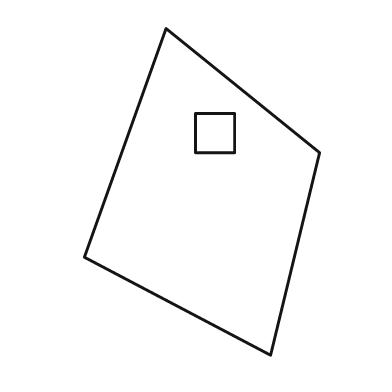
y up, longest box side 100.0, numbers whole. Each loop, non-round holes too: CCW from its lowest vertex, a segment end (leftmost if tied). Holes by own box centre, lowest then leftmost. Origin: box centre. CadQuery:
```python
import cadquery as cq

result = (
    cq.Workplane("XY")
    .moveTo(21.0, -50.0)
    .lineTo(36.0, 12.0)
    .lineTo(-11.0, 50.0)
    .lineTo(-36.0, -20.0)
    .close()
    .moveTo(-2.0, 12.0)
    .lineTo(10.0, 12.0)
    .lineTo(10.0, 24.0)
    .lineTo(-2.0, 24.0)
    .close()
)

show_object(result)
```